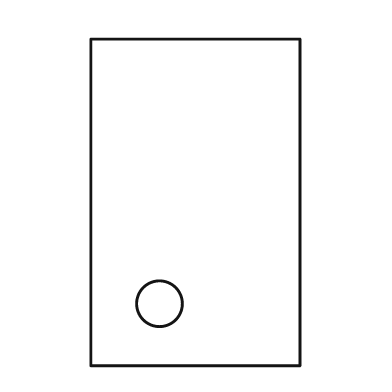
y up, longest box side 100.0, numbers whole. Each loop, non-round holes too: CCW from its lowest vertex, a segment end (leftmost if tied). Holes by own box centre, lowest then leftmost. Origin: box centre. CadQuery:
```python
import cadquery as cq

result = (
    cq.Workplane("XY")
    .moveTo(-32.0, -50.0)
    .lineTo(32.0, -50.0)
    .lineTo(32.0, 50.0)
    .lineTo(-32.0, 50.0)
    .close()
    .moveTo(-11.0, -31.0)
    .circle(7.0)
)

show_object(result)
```